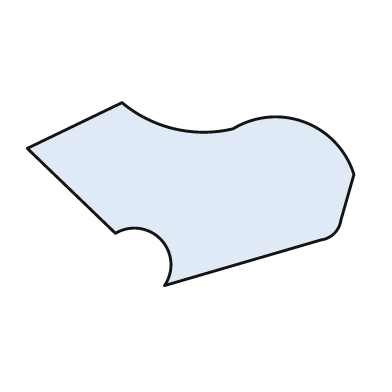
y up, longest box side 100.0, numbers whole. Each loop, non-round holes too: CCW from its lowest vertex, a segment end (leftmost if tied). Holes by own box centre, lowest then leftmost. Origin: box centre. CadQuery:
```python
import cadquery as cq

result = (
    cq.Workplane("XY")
    .moveTo(-8.0, -28.0)
    .lineTo(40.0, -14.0)
    .threePointArc((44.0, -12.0), (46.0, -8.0))
    .lineTo(50.0, 6.0)
    .threePointArc((35.0, 22.0), (13.0, 20.0))
    .threePointArc((-5.0, 20.0), (-21.0, 28.0))
    .lineTo(-50.0, 14.0)
    .lineTo(-23.0, -12.0)
    .threePointArc((-9.0, -14.0), (-8.0, -28.0))
    .close()
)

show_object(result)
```